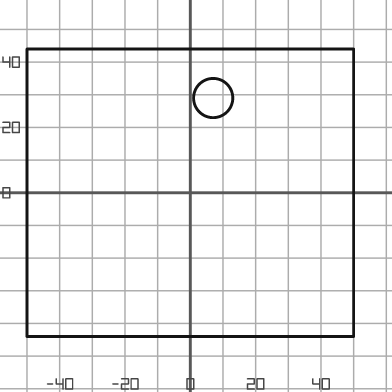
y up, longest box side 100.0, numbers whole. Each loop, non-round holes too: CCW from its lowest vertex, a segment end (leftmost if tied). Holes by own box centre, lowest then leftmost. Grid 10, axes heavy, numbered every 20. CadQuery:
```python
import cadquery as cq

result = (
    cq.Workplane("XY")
    .moveTo(-50.0, -44.0)
    .lineTo(50.0, -44.0)
    .lineTo(50.0, 44.0)
    .lineTo(-50.0, 44.0)
    .close()
    .moveTo(7.0, 29.0)
    .circle(6.0)
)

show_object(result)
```